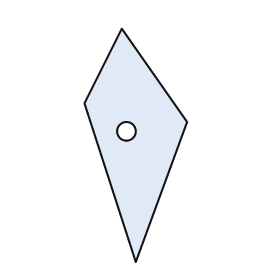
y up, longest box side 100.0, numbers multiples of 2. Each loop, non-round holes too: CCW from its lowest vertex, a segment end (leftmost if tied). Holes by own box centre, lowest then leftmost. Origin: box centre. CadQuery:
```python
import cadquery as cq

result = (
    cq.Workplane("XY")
    .moveTo(0.0, -50.0)
    .lineTo(22.0, 10.0)
    .lineTo(-6.0, 50.0)
    .lineTo(-22.0, 18.0)
    .close()
    .moveTo(-4.0, 6.0)
    .circle(4.0)
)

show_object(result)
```